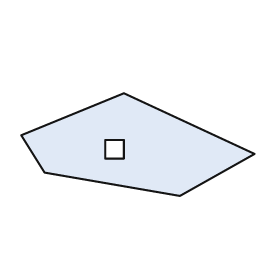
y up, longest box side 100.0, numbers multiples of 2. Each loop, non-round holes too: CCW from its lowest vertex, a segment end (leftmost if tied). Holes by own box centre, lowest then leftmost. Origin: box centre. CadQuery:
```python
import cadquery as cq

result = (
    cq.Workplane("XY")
    .moveTo(18.0, -22.0)
    .lineTo(50.0, -4.0)
    .lineTo(-6.0, 22.0)
    .lineTo(-50.0, 4.0)
    .lineTo(-40.0, -12.0)
    .close()
    .moveTo(-14.0, -6.0)
    .lineTo(-6.0, -6.0)
    .lineTo(-6.0, 2.0)
    .lineTo(-14.0, 2.0)
    .close()
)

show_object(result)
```